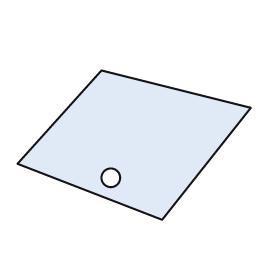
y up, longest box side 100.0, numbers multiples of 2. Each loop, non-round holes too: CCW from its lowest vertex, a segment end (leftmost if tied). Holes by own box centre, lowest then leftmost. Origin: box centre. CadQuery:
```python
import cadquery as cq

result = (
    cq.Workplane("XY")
    .moveTo(12.0, -32.0)
    .lineTo(50.0, 16.0)
    .lineTo(-14.0, 32.0)
    .lineTo(-50.0, -8.0)
    .close()
    .moveTo(-10.0, -14.0)
    .circle(4.0)
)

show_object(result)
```